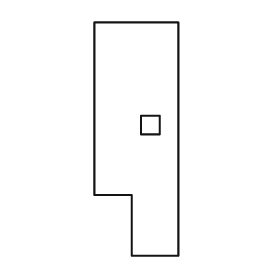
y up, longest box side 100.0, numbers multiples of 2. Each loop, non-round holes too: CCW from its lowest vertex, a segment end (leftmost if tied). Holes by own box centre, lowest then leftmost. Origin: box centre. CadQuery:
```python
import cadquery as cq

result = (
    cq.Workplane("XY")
    .moveTo(-2.0, -50.0)
    .lineTo(18.0, -50.0)
    .lineTo(18.0, 50.0)
    .lineTo(-18.0, 50.0)
    .lineTo(-18.0, -24.0)
    .lineTo(-2.0, -24.0)
    .close()
    .moveTo(2.0, 2.0)
    .lineTo(10.0, 2.0)
    .lineTo(10.0, 10.0)
    .lineTo(2.0, 10.0)
    .close()
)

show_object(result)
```